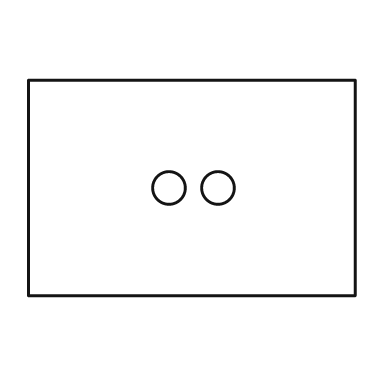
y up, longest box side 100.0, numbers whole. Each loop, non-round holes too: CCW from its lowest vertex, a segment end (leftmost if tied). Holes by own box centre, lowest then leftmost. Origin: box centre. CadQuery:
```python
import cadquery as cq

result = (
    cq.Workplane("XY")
    .moveTo(-50.0, -33.0)
    .lineTo(50.0, -33.0)
    .lineTo(50.0, 33.0)
    .lineTo(-50.0, 33.0)
    .close()
    .moveTo(-7.0, 0.0)
    .circle(5.0)
    .moveTo(8.0, 0.0)
    .circle(5.0)
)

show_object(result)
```